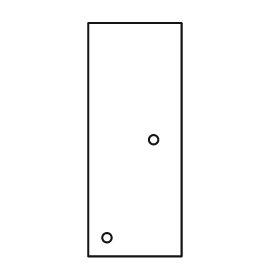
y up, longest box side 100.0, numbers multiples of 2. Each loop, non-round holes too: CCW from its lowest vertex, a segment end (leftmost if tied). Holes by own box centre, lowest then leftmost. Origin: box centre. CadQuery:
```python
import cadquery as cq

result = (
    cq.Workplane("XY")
    .moveTo(-20.0, -50.0)
    .lineTo(20.0, -50.0)
    .lineTo(20.0, 50.0)
    .lineTo(-20.0, 50.0)
    .close()
    .moveTo(-12.0, -42.0)
    .circle(2.0)
    .moveTo(8.0, 0.0)
    .circle(2.0)
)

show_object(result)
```